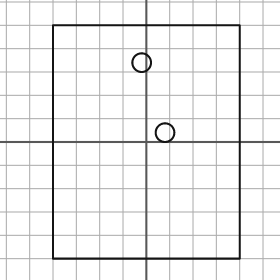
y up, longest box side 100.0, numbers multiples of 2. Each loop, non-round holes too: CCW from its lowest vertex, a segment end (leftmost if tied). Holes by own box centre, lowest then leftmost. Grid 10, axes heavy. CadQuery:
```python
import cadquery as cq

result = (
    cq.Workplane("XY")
    .moveTo(-40.0, -50.0)
    .lineTo(40.0, -50.0)
    .lineTo(40.0, 50.0)
    .lineTo(-40.0, 50.0)
    .close()
    .moveTo(8.0, 4.0)
    .circle(4.0)
    .moveTo(-2.0, 34.0)
    .circle(4.0)
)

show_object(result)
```